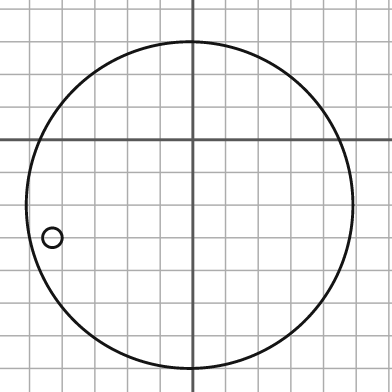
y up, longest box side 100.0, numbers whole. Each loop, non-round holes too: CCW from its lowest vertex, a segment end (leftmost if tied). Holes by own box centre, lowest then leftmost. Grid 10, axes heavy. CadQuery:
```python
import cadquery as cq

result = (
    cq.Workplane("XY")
    .moveTo(-1.0, -20.0)
    .circle(50.0)
    .moveTo(-43.0, -30.0)
    .circle(3.0)
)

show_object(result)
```